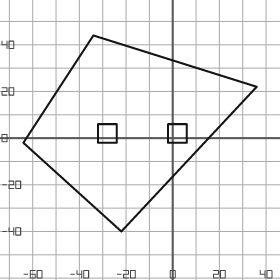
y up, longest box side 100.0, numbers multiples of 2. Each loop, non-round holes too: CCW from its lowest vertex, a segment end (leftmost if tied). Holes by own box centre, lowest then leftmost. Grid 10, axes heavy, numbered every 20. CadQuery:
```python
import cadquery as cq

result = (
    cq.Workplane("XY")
    .moveTo(-22.0, -40.0)
    .lineTo(36.0, 22.0)
    .lineTo(-34.0, 44.0)
    .lineTo(-64.0, -2.0)
    .close()
    .moveTo(-32.0, -2.0)
    .lineTo(-24.0, -2.0)
    .lineTo(-24.0, 6.0)
    .lineTo(-32.0, 6.0)
    .close()
    .moveTo(-2.0, -2.0)
    .lineTo(6.0, -2.0)
    .lineTo(6.0, 6.0)
    .lineTo(-2.0, 6.0)
    .close()
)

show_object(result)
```